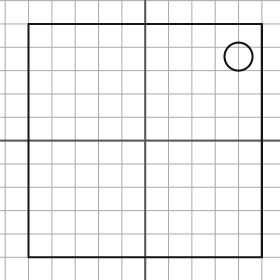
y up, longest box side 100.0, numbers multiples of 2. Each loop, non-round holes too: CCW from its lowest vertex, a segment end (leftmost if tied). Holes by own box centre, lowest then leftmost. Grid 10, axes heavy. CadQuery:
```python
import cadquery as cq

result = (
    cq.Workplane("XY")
    .moveTo(-50.0, -50.0)
    .lineTo(50.0, -50.0)
    .lineTo(50.0, 50.0)
    .lineTo(-50.0, 50.0)
    .close()
    .moveTo(40.0, 36.0)
    .circle(6.0)
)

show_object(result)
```